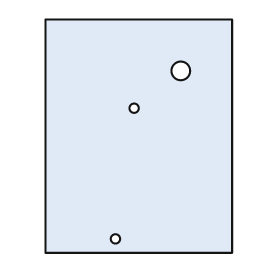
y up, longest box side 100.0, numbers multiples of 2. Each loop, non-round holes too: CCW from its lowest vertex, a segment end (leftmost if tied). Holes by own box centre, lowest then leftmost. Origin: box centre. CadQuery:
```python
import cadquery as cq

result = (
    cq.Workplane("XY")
    .moveTo(-40.0, -50.0)
    .lineTo(40.0, -50.0)
    .lineTo(40.0, 50.0)
    .lineTo(-40.0, 50.0)
    .close()
    .moveTo(-10.0, -44.0)
    .circle(2.0)
    .moveTo(-2.0, 12.0)
    .circle(2.0)
    .moveTo(18.0, 28.0)
    .circle(4.0)
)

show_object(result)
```